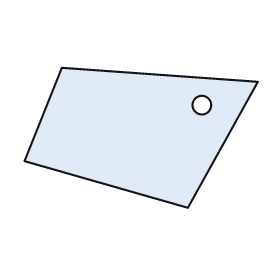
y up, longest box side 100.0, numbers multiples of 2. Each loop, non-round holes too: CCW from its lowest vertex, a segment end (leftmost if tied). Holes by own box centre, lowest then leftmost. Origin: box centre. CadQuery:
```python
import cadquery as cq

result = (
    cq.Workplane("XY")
    .moveTo(20.0, -30.0)
    .lineTo(50.0, 24.0)
    .lineTo(-34.0, 30.0)
    .lineTo(-50.0, -10.0)
    .close()
    .moveTo(26.0, 14.0)
    .circle(4.0)
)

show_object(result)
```